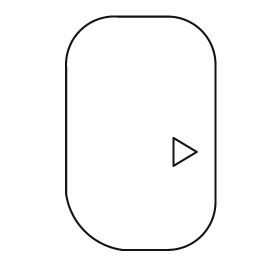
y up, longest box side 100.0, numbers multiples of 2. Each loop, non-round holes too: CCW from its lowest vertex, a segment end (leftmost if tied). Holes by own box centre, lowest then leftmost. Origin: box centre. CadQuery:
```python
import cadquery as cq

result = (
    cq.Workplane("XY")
    .moveTo(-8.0, -50.0)
    .lineTo(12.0, -50.0)
    .threePointArc((26.0, -44.0), (32.0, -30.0))
    .lineTo(32.0, 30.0)
    .threePointArc((26.0, 44.0), (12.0, 50.0))
    .lineTo(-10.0, 50.0)
    .threePointArc((-26.0, 44.0), (-32.0, 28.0))
    .lineTo(-32.0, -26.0)
    .threePointArc((-24.0, -42.0), (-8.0, -50.0))
    .close()
    .moveTo(14.0, -14.0)
    .lineTo(24.0, -8.0)
    .lineTo(14.0, -2.0)
    .close()
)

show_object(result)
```